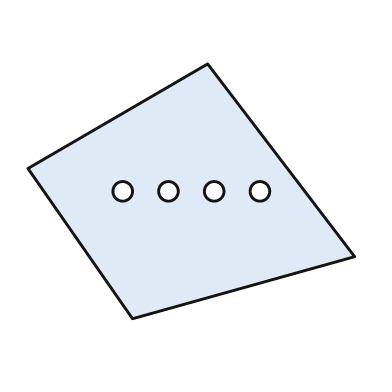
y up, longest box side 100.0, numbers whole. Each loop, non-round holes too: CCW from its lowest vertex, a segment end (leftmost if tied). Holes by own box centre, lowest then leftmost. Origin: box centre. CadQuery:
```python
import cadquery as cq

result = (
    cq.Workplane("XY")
    .moveTo(-18.0, -39.0)
    .lineTo(50.0, -20.0)
    .lineTo(5.0, 39.0)
    .lineTo(-50.0, 7.0)
    .close()
    .moveTo(-21.0, 0.0)
    .circle(3.0)
    .moveTo(-7.0, 0.0)
    .circle(3.0)
    .moveTo(7.0, 0.0)
    .circle(3.0)
    .moveTo(21.0, 0.0)
    .circle(3.0)
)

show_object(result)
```